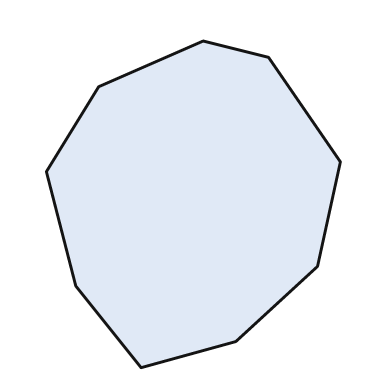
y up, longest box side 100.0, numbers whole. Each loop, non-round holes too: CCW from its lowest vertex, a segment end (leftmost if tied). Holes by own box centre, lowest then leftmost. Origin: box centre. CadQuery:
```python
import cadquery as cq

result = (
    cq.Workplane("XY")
    .moveTo(-16.0, -50.0)
    .lineTo(13.0, -42.0)
    .lineTo(38.0, -19.0)
    .lineTo(45.0, 13.0)
    .lineTo(23.0, 45.0)
    .lineTo(3.0, 50.0)
    .lineTo(-29.0, 36.0)
    .lineTo(-45.0, 10.0)
    .lineTo(-36.0, -25.0)
    .close()
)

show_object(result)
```